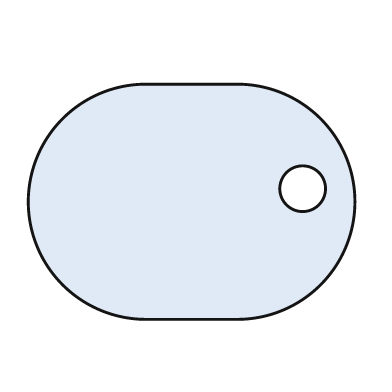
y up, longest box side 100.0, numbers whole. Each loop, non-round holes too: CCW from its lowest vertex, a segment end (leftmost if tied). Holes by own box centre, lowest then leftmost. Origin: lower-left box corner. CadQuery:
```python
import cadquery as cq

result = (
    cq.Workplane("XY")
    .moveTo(36.0, 0.0)
    .lineTo(64.0, 0.0)
    .threePointArc((100.0, 36.0), (64.0, 72.0))
    .lineTo(36.0, 72.0)
    .threePointArc((0.0, 36.0), (36.0, 0.0))
    .close()
    .moveTo(84.0, 40.0)
    .circle(7.0)
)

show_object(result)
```